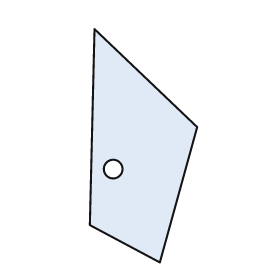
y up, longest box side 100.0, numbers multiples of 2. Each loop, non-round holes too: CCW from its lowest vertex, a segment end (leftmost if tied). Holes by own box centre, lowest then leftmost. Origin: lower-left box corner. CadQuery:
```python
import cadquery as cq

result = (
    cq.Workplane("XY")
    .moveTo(30.0, 0.0)
    .lineTo(46.0, 58.0)
    .lineTo(2.0, 100.0)
    .lineTo(0.0, 16.0)
    .close()
    .moveTo(10.0, 40.0)
    .circle(4.0)
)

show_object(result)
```